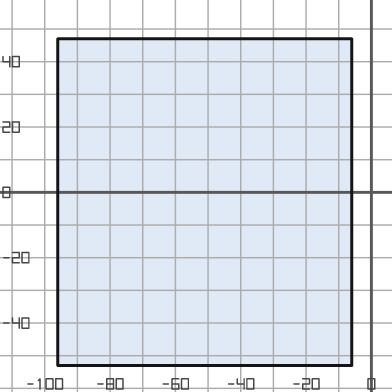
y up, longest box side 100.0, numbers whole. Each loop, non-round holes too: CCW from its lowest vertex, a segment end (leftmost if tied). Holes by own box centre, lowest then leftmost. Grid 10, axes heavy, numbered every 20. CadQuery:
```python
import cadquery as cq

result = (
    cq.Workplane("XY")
    .moveTo(-96.0, -53.0)
    .lineTo(-6.0, -53.0)
    .lineTo(-6.0, 47.0)
    .lineTo(-96.0, 47.0)
    .close()
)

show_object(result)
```